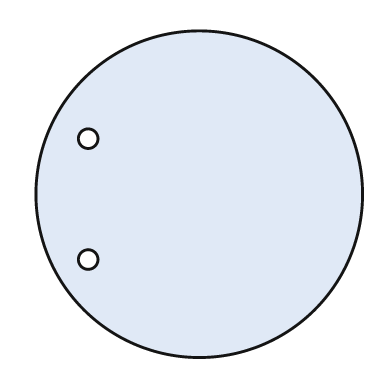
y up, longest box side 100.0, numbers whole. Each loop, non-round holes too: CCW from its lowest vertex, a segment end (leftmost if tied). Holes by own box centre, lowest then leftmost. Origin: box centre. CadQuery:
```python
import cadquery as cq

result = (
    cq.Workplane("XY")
    .moveTo(0.0, 0.0)
    .circle(50.0)
    .moveTo(-34.0, -20.0)
    .circle(3.0)
    .moveTo(-34.0, 17.0)
    .circle(3.0)
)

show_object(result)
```